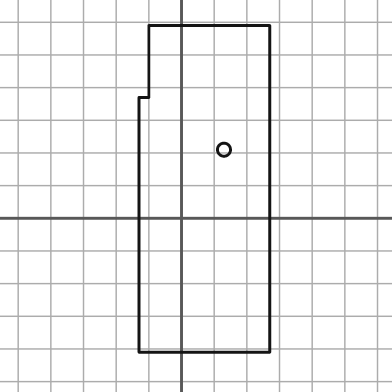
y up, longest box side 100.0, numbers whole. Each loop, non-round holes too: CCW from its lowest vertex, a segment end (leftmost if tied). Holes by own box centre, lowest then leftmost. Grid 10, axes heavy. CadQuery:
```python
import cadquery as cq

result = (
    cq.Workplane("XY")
    .moveTo(-13.0, -41.0)
    .lineTo(27.0, -41.0)
    .lineTo(27.0, 59.0)
    .lineTo(-10.0, 59.0)
    .lineTo(-10.0, 37.0)
    .lineTo(-13.0, 37.0)
    .close()
    .moveTo(13.0, 21.0)
    .circle(2.0)
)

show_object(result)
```